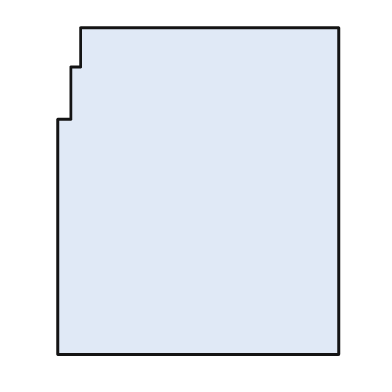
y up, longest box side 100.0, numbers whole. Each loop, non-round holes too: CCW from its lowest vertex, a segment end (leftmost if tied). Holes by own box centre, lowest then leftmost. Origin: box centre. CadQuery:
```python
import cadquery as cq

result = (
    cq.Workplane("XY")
    .moveTo(-43.0, -50.0)
    .lineTo(43.0, -50.0)
    .lineTo(43.0, 50.0)
    .lineTo(-36.0, 50.0)
    .lineTo(-36.0, 38.0)
    .lineTo(-39.0, 38.0)
    .lineTo(-39.0, 22.0)
    .lineTo(-43.0, 22.0)
    .close()
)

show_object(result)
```